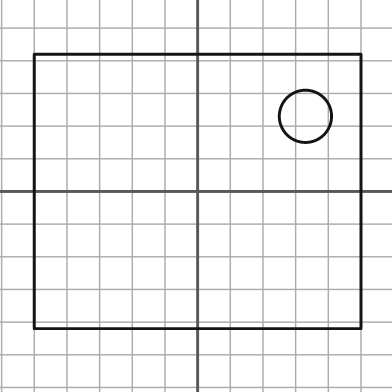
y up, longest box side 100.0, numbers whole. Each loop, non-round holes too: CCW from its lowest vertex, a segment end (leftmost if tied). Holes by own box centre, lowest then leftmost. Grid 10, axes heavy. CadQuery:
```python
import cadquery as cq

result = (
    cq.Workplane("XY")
    .moveTo(-50.0, -42.0)
    .lineTo(50.0, -42.0)
    .lineTo(50.0, 42.0)
    .lineTo(-50.0, 42.0)
    .close()
    .moveTo(33.0, 23.0)
    .circle(8.0)
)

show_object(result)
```